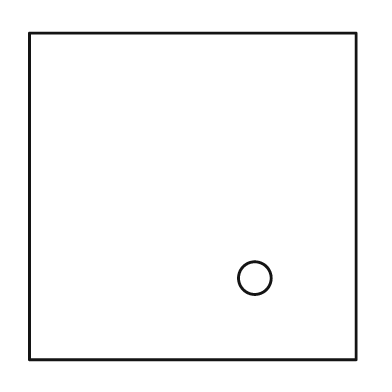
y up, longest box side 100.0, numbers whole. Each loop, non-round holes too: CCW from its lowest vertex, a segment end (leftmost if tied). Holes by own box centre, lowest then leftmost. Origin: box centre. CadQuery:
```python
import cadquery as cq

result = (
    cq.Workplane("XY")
    .moveTo(-50.0, -50.0)
    .lineTo(50.0, -50.0)
    .lineTo(50.0, 50.0)
    .lineTo(-50.0, 50.0)
    .close()
    .moveTo(19.0, -25.0)
    .circle(5.0)
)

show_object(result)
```